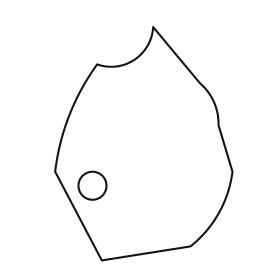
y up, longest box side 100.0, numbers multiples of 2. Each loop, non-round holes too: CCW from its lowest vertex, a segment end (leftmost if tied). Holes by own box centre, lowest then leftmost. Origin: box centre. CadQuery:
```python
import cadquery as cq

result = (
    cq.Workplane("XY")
    .moveTo(-18.0, -50.0)
    .lineTo(20.0, -44.0)
    .threePointArc((32.0, -30.0), (38.0, -12.0))
    .lineTo(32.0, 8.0)
    .threePointArc((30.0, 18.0), (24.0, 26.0))
    .lineTo(4.0, 50.0)
    .threePointArc((-4.0, 36.0), (-20.0, 34.0))
    .threePointArc((-32.0, 12.0), (-38.0, -12.0))
    .close()
    .moveTo(-22.0, -18.0)
    .circle(6.0)
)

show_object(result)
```